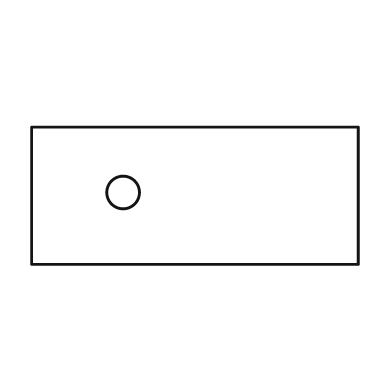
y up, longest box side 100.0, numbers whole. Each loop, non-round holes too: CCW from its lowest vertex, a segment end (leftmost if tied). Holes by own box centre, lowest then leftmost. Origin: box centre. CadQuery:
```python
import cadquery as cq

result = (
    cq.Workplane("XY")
    .moveTo(-50.0, -21.0)
    .lineTo(50.0, -21.0)
    .lineTo(50.0, 21.0)
    .lineTo(-50.0, 21.0)
    .close()
    .moveTo(-22.0, 1.0)
    .circle(5.0)
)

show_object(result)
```